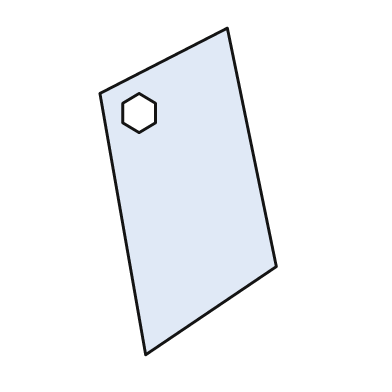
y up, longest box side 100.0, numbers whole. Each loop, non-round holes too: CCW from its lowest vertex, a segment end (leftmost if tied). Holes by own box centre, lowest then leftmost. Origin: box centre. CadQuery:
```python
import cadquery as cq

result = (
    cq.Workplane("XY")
    .moveTo(-13.0, -50.0)
    .lineTo(27.0, -23.0)
    .lineTo(12.0, 50.0)
    .lineTo(-27.0, 30.0)
    .close()
    .moveTo(-15.0, 18.0)
    .lineTo(-10.0, 21.0)
    .lineTo(-10.0, 27.0)
    .lineTo(-15.0, 30.0)
    .lineTo(-20.0, 27.0)
    .lineTo(-20.0, 21.0)
    .close()
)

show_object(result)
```